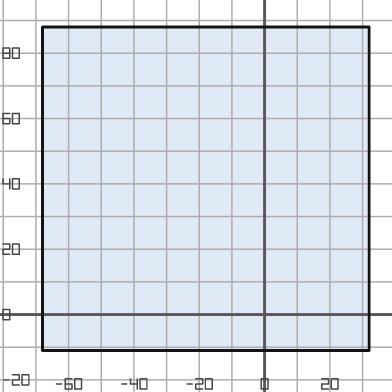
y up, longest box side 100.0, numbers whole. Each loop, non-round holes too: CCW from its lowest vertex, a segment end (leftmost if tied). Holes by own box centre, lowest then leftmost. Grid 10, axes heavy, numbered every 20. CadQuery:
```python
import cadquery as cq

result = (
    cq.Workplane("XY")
    .moveTo(-68.0, -11.0)
    .lineTo(32.0, -11.0)
    .lineTo(32.0, 88.0)
    .lineTo(-68.0, 88.0)
    .close()
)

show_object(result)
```